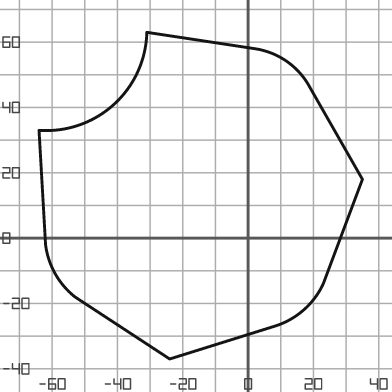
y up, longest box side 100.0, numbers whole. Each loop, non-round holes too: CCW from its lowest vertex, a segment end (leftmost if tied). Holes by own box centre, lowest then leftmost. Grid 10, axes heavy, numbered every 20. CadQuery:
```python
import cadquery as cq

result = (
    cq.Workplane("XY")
    .moveTo(-24.0, -37.0)
    .lineTo(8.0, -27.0)
    .threePointArc((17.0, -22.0), (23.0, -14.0))
    .lineTo(35.0, 18.0)
    .lineTo(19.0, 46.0)
    .threePointArc((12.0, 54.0), (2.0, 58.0))
    .lineTo(-31.0, 63.0)
    .threePointArc((-41.0, 41.0), (-64.0, 33.0))
    .lineTo(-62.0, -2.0)
    .threePointArc((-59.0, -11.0), (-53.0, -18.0))
    .close()
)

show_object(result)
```